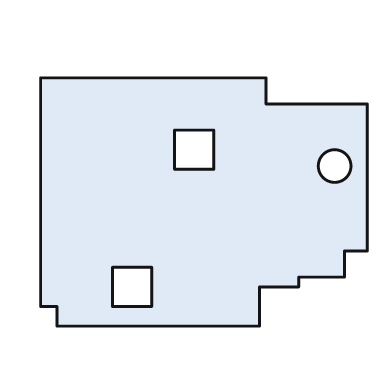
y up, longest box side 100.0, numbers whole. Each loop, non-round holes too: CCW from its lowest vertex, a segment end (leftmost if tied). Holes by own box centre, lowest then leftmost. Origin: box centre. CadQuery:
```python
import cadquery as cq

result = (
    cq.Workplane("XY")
    .moveTo(-45.0, -38.0)
    .lineTo(17.0, -38.0)
    .lineTo(17.0, -26.0)
    .lineTo(29.0, -26.0)
    .lineTo(29.0, -23.0)
    .lineTo(43.0, -23.0)
    .lineTo(43.0, -15.0)
    .lineTo(50.0, -15.0)
    .lineTo(50.0, 30.0)
    .lineTo(19.0, 30.0)
    .lineTo(19.0, 38.0)
    .lineTo(-50.0, 38.0)
    .lineTo(-50.0, -32.0)
    .lineTo(-45.0, -32.0)
    .close()
    .moveTo(-28.0, -32.0)
    .lineTo(-16.0, -32.0)
    .lineTo(-16.0, -20.0)
    .lineTo(-28.0, -20.0)
    .close()
    .moveTo(40.0, 11.0)
    .circle(5.0)
    .moveTo(-9.0, 10.0)
    .lineTo(3.0, 10.0)
    .lineTo(3.0, 22.0)
    .lineTo(-9.0, 22.0)
    .close()
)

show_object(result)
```